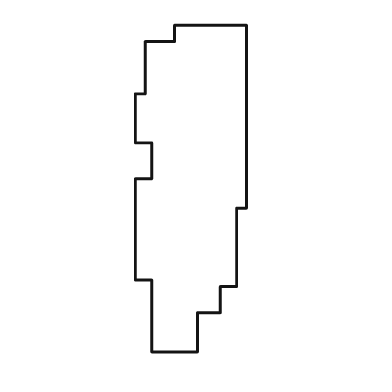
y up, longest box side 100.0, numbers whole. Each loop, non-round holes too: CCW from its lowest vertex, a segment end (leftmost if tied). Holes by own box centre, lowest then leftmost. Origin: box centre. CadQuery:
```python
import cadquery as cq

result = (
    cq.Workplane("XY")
    .moveTo(-12.0, -50.0)
    .lineTo(2.0, -50.0)
    .lineTo(2.0, -38.0)
    .lineTo(9.0, -38.0)
    .lineTo(9.0, -30.0)
    .lineTo(14.0, -30.0)
    .lineTo(14.0, -6.0)
    .lineTo(17.0, -6.0)
    .lineTo(17.0, 50.0)
    .lineTo(-5.0, 50.0)
    .lineTo(-5.0, 45.0)
    .lineTo(-14.0, 45.0)
    .lineTo(-14.0, 29.0)
    .lineTo(-17.0, 29.0)
    .lineTo(-17.0, 14.0)
    .lineTo(-12.0, 14.0)
    .lineTo(-12.0, 3.0)
    .lineTo(-17.0, 3.0)
    .lineTo(-17.0, -28.0)
    .lineTo(-12.0, -28.0)
    .close()
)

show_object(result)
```